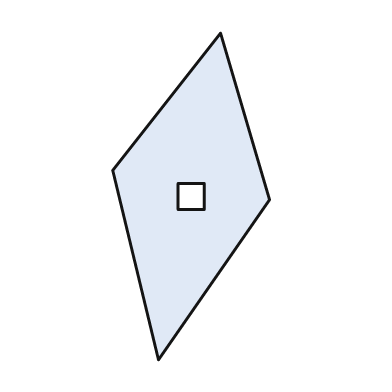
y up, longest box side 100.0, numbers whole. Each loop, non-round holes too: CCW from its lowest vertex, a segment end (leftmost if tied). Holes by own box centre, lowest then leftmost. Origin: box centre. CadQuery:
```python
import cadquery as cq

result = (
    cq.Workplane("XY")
    .moveTo(-10.0, -50.0)
    .lineTo(24.0, -1.0)
    .lineTo(9.0, 50.0)
    .lineTo(-24.0, 8.0)
    .close()
    .moveTo(-4.0, -4.0)
    .lineTo(4.0, -4.0)
    .lineTo(4.0, 4.0)
    .lineTo(-4.0, 4.0)
    .close()
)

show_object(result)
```